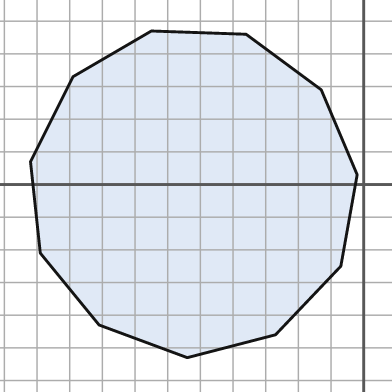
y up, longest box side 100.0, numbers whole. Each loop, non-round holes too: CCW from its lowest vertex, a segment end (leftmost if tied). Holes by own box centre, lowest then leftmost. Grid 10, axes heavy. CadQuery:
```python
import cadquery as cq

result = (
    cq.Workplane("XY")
    .moveTo(-54.0, -53.0)
    .lineTo(-27.0, -46.0)
    .lineTo(-7.0, -25.0)
    .lineTo(-2.0, 3.0)
    .lineTo(-13.0, 29.0)
    .lineTo(-36.0, 46.0)
    .lineTo(-65.0, 47.0)
    .lineTo(-89.0, 33.0)
    .lineTo(-102.0, 7.0)
    .lineTo(-99.0, -21.0)
    .lineTo(-81.0, -43.0)
    .close()
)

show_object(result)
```